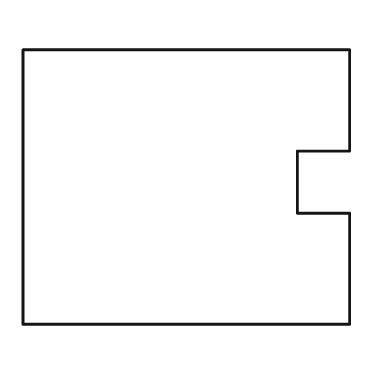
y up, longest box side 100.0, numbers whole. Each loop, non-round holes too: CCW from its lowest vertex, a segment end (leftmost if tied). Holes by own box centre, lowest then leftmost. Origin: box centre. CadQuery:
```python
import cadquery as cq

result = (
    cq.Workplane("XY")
    .moveTo(-50.0, -42.0)
    .lineTo(50.0, -42.0)
    .lineTo(50.0, -8.0)
    .lineTo(34.0, -8.0)
    .lineTo(34.0, 11.0)
    .lineTo(50.0, 11.0)
    .lineTo(50.0, 42.0)
    .lineTo(-50.0, 42.0)
    .close()
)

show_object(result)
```